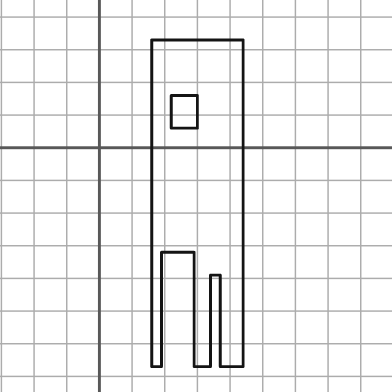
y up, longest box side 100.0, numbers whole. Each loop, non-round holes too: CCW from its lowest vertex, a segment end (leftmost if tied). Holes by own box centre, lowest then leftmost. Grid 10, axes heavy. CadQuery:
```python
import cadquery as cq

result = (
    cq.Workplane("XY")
    .moveTo(16.0, -67.0)
    .lineTo(19.0, -67.0)
    .lineTo(19.0, -32.0)
    .lineTo(29.0, -32.0)
    .lineTo(29.0, -67.0)
    .lineTo(34.0, -67.0)
    .lineTo(34.0, -39.0)
    .lineTo(37.0, -39.0)
    .lineTo(37.0, -67.0)
    .lineTo(44.0, -67.0)
    .lineTo(44.0, 33.0)
    .lineTo(16.0, 33.0)
    .close()
    .moveTo(22.0, 6.0)
    .lineTo(30.0, 6.0)
    .lineTo(30.0, 16.0)
    .lineTo(22.0, 16.0)
    .close()
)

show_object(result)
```